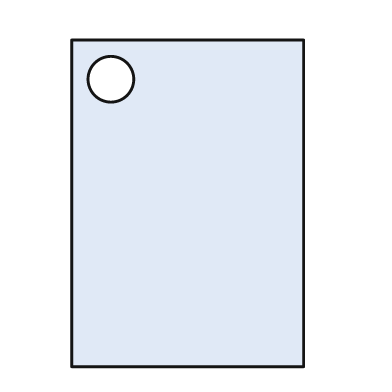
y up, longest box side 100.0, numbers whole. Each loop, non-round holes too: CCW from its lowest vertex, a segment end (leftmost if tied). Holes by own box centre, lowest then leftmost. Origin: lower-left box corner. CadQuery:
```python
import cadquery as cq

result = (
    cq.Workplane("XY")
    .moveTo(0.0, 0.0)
    .lineTo(71.0, 0.0)
    .lineTo(71.0, 100.0)
    .lineTo(0.0, 100.0)
    .close()
    .moveTo(12.0, 88.0)
    .circle(7.0)
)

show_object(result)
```